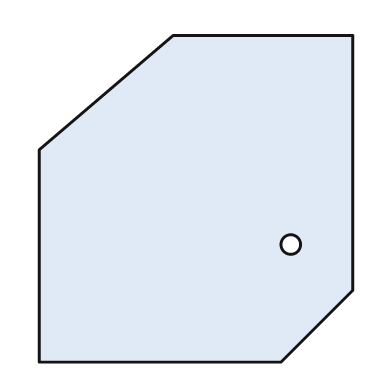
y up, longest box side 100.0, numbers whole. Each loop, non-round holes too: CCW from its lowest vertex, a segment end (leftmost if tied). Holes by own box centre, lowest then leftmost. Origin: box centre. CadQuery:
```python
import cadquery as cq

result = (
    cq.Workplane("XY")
    .moveTo(-48.0, -50.0)
    .lineTo(26.0, -50.0)
    .lineTo(48.0, -28.0)
    .lineTo(48.0, 50.0)
    .lineTo(-7.0, 50.0)
    .lineTo(-48.0, 15.0)
    .close()
    .moveTo(29.0, -14.0)
    .circle(3.0)
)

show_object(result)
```